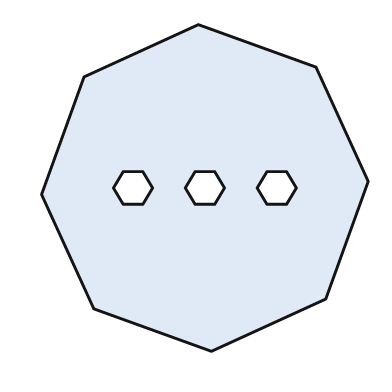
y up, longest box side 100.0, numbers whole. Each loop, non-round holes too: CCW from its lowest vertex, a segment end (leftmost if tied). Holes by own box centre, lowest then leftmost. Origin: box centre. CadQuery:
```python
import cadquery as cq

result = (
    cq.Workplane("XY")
    .moveTo(2.0, -50.0)
    .lineTo(37.0, -34.0)
    .lineTo(50.0, 2.0)
    .lineTo(34.0, 37.0)
    .lineTo(-2.0, 50.0)
    .lineTo(-37.0, 34.0)
    .lineTo(-50.0, -2.0)
    .lineTo(-34.0, -37.0)
    .close()
    .moveTo(-25.0, -5.0)
    .lineTo(-19.0, -5.0)
    .lineTo(-16.0, 0.0)
    .lineTo(-19.0, 5.0)
    .lineTo(-25.0, 5.0)
    .lineTo(-28.0, 0.0)
    .close()
    .moveTo(-3.0, -5.0)
    .lineTo(3.0, -5.0)
    .lineTo(6.0, 0.0)
    .lineTo(3.0, 5.0)
    .lineTo(-3.0, 5.0)
    .lineTo(-6.0, 0.0)
    .close()
    .moveTo(19.0, -5.0)
    .lineTo(25.0, -5.0)
    .lineTo(28.0, 0.0)
    .lineTo(25.0, 5.0)
    .lineTo(19.0, 5.0)
    .lineTo(16.0, 0.0)
    .close()
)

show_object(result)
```